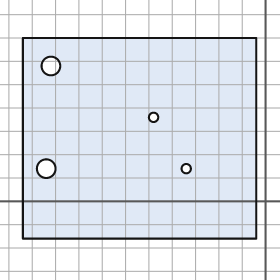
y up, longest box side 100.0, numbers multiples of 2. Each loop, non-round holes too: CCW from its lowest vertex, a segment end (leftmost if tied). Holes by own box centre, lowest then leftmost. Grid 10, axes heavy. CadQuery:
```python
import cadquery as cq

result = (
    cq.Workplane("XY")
    .moveTo(-104.0, -16.0)
    .lineTo(-4.0, -16.0)
    .lineTo(-4.0, 70.0)
    .lineTo(-104.0, 70.0)
    .close()
    .moveTo(-94.0, 14.0)
    .circle(4.0)
    .moveTo(-34.0, 14.0)
    .circle(2.0)
    .moveTo(-48.0, 36.0)
    .circle(2.0)
    .moveTo(-92.0, 58.0)
    .circle(4.0)
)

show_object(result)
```